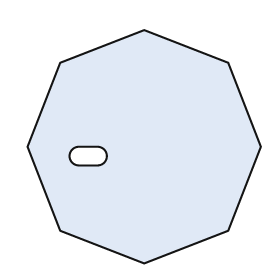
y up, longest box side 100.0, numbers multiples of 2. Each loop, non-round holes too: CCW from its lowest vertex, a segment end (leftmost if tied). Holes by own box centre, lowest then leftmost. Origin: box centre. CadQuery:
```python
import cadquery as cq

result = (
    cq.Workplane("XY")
    .moveTo(0.0, -50.0)
    .lineTo(36.0, -36.0)
    .lineTo(50.0, 0.0)
    .lineTo(36.0, 36.0)
    .lineTo(0.0, 50.0)
    .lineTo(-36.0, 36.0)
    .lineTo(-50.0, 0.0)
    .lineTo(-36.0, -36.0)
    .close()
    .moveTo(-28.0, -8.0)
    .lineTo(-20.0, -8.0)
    .threePointArc((-16.0, -4.0), (-20.0, 0.0))
    .lineTo(-28.0, 0.0)
    .threePointArc((-32.0, -4.0), (-28.0, -8.0))
    .close()
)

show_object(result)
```